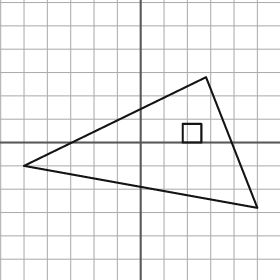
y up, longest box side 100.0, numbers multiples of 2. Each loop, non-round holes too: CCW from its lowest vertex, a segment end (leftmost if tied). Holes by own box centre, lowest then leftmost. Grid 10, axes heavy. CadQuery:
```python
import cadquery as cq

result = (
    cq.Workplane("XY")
    .moveTo(50.0, -28.0)
    .lineTo(28.0, 28.0)
    .lineTo(-50.0, -10.0)
    .close()
    .moveTo(18.0, 0.0)
    .lineTo(26.0, 0.0)
    .lineTo(26.0, 8.0)
    .lineTo(18.0, 8.0)
    .close()
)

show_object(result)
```